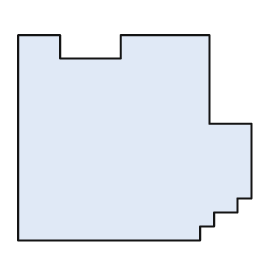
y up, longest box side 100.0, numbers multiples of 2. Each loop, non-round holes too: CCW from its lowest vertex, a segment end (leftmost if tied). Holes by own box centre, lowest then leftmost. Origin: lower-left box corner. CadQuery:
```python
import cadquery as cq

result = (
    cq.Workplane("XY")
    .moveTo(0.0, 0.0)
    .lineTo(78.0, 0.0)
    .lineTo(78.0, 6.0)
    .lineTo(84.0, 6.0)
    .lineTo(84.0, 12.0)
    .lineTo(94.0, 12.0)
    .lineTo(94.0, 18.0)
    .lineTo(100.0, 18.0)
    .lineTo(100.0, 50.0)
    .lineTo(82.0, 50.0)
    .lineTo(82.0, 88.0)
    .lineTo(44.0, 88.0)
    .lineTo(44.0, 78.0)
    .lineTo(18.0, 78.0)
    .lineTo(18.0, 88.0)
    .lineTo(0.0, 88.0)
    .close()
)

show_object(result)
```